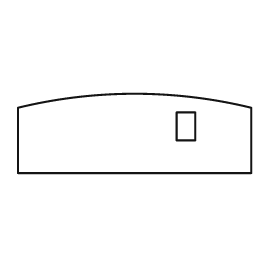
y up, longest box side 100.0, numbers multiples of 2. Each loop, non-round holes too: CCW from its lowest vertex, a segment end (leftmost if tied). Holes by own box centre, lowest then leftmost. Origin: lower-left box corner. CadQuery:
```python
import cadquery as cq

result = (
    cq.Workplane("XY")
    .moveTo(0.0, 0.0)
    .lineTo(100.0, 0.0)
    .lineTo(100.0, 28.0)
    .threePointArc((50.0, 34.0), (0.0, 28.0))
    .close()
    .moveTo(68.0, 14.0)
    .lineTo(76.0, 14.0)
    .lineTo(76.0, 26.0)
    .lineTo(68.0, 26.0)
    .close()
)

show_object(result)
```